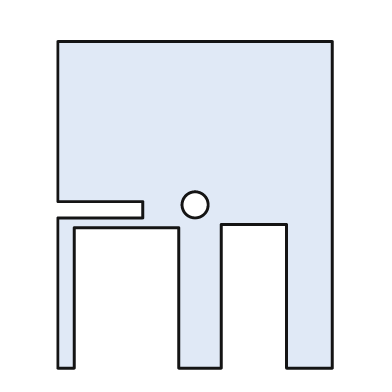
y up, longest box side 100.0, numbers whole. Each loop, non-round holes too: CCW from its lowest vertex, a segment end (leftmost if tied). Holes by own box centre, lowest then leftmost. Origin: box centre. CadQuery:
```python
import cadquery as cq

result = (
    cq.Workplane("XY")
    .moveTo(-42.0, -50.0)
    .lineTo(-37.0, -50.0)
    .lineTo(-37.0, -7.0)
    .lineTo(-5.0, -7.0)
    .lineTo(-5.0, -50.0)
    .lineTo(8.0, -50.0)
    .lineTo(8.0, -6.0)
    .lineTo(28.0, -6.0)
    .lineTo(28.0, -50.0)
    .lineTo(42.0, -50.0)
    .lineTo(42.0, 50.0)
    .lineTo(-42.0, 50.0)
    .lineTo(-42.0, 1.0)
    .lineTo(-16.0, 1.0)
    .lineTo(-16.0, -4.0)
    .lineTo(-42.0, -4.0)
    .close()
    .moveTo(0.0, 0.0)
    .circle(4.0)
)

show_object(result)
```